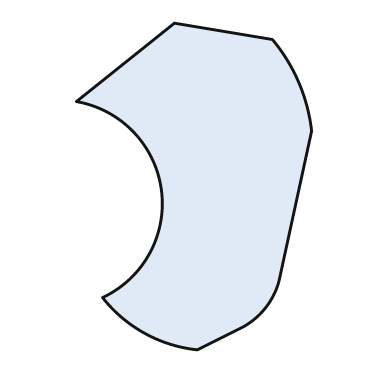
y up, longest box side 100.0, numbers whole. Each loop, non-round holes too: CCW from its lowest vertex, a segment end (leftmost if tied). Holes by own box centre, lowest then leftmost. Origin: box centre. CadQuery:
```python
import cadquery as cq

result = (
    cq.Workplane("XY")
    .moveTo(1.0, -50.0)
    .lineTo(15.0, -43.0)
    .threePointArc((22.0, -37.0), (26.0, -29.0))
    .lineTo(36.0, 17.0)
    .threePointArc((32.0, 32.0), (24.0, 45.0))
    .lineTo(-6.0, 50.0)
    .lineTo(-36.0, 26.0)
    .threePointArc((-10.0, -1.0), (-28.0, -34.0))
    .threePointArc((-15.0, -45.0), (1.0, -50.0))
    .close()
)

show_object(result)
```